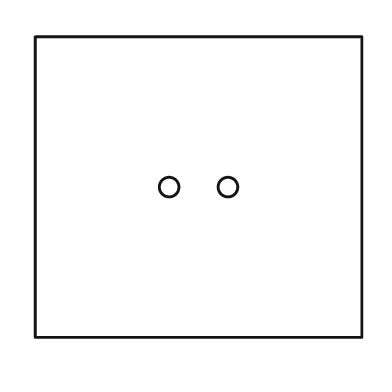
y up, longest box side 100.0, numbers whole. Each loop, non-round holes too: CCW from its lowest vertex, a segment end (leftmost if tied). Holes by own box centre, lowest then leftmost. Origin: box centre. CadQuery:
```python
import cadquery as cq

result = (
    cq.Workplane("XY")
    .moveTo(-50.0, -46.0)
    .lineTo(50.0, -46.0)
    .lineTo(50.0, 46.0)
    .lineTo(-50.0, 46.0)
    .close()
    .moveTo(-9.0, 0.0)
    .circle(3.0)
    .moveTo(9.0, 0.0)
    .circle(3.0)
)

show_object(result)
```